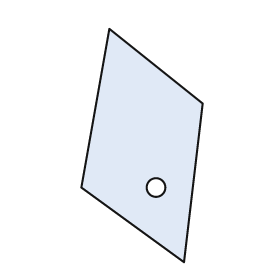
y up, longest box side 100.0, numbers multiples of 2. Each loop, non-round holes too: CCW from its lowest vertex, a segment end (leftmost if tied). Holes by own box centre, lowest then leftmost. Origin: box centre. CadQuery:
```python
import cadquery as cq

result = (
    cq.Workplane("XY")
    .moveTo(18.0, -50.0)
    .lineTo(26.0, 18.0)
    .lineTo(-14.0, 50.0)
    .lineTo(-26.0, -18.0)
    .close()
    .moveTo(6.0, -18.0)
    .circle(4.0)
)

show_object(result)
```